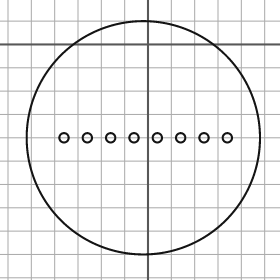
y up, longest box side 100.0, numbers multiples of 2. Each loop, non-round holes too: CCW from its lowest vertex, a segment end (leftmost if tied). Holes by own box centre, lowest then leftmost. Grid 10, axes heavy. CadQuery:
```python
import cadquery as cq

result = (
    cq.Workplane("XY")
    .moveTo(-2.0, -40.0)
    .circle(50.0)
    .moveTo(-36.0, -40.0)
    .circle(2.0)
    .moveTo(-26.0, -40.0)
    .circle(2.0)
    .moveTo(-16.0, -40.0)
    .circle(2.0)
    .moveTo(-6.0, -40.0)
    .circle(2.0)
    .moveTo(4.0, -40.0)
    .circle(2.0)
    .moveTo(14.0, -40.0)
    .circle(2.0)
    .moveTo(24.0, -40.0)
    .circle(2.0)
    .moveTo(34.0, -40.0)
    .circle(2.0)
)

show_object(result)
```